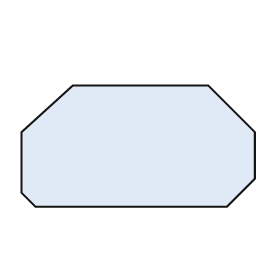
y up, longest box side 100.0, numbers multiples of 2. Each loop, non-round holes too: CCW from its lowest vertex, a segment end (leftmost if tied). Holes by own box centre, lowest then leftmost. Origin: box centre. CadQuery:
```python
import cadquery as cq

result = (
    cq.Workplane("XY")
    .moveTo(-44.0, -26.0)
    .lineTo(38.0, -26.0)
    .lineTo(50.0, -14.0)
    .lineTo(50.0, 6.0)
    .lineTo(30.0, 26.0)
    .lineTo(-28.0, 26.0)
    .lineTo(-50.0, 6.0)
    .lineTo(-50.0, -20.0)
    .close()
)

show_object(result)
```